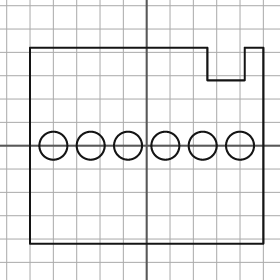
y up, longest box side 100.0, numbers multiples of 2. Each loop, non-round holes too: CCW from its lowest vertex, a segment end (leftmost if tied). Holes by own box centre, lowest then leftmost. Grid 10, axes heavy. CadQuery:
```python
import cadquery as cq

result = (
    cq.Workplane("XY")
    .moveTo(-50.0, -42.0)
    .lineTo(50.0, -42.0)
    .lineTo(50.0, 42.0)
    .lineTo(42.0, 42.0)
    .lineTo(42.0, 28.0)
    .lineTo(26.0, 28.0)
    .lineTo(26.0, 42.0)
    .lineTo(-50.0, 42.0)
    .close()
    .moveTo(-40.0, 0.0)
    .circle(6.0)
    .moveTo(-24.0, 0.0)
    .circle(6.0)
    .moveTo(-8.0, 0.0)
    .circle(6.0)
    .moveTo(8.0, 0.0)
    .circle(6.0)
    .moveTo(24.0, 0.0)
    .circle(6.0)
    .moveTo(40.0, 0.0)
    .circle(6.0)
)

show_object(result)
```